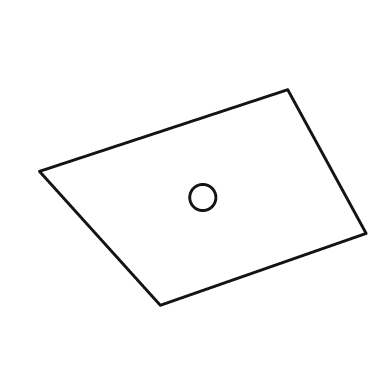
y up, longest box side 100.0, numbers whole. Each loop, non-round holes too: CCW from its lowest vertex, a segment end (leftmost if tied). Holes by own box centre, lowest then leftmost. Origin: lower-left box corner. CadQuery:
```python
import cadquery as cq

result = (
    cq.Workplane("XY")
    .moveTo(37.0, 0.0)
    .lineTo(100.0, 22.0)
    .lineTo(76.0, 66.0)
    .lineTo(0.0, 41.0)
    .close()
    .moveTo(50.0, 33.0)
    .circle(4.0)
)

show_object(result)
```